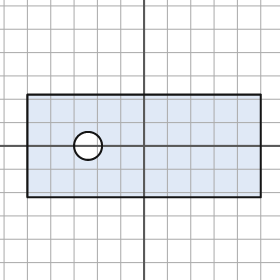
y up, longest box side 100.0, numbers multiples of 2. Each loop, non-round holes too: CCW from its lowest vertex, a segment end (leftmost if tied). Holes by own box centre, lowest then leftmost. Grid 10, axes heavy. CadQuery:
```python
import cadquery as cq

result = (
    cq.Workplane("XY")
    .moveTo(-50.0, -22.0)
    .lineTo(50.0, -22.0)
    .lineTo(50.0, 22.0)
    .lineTo(-50.0, 22.0)
    .close()
    .moveTo(-24.0, 0.0)
    .circle(6.0)
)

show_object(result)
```